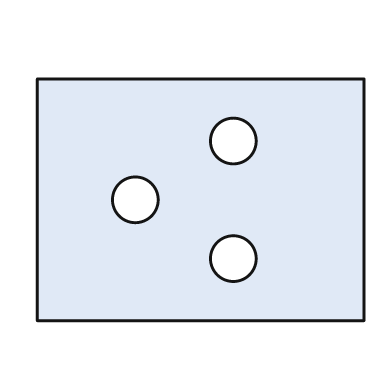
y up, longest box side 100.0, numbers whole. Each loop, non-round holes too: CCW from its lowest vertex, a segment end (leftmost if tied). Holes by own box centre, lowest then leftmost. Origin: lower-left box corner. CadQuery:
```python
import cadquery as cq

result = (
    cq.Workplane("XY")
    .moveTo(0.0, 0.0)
    .lineTo(100.0, 0.0)
    .lineTo(100.0, 74.0)
    .lineTo(0.0, 74.0)
    .close()
    .moveTo(60.0, 19.0)
    .circle(7.0)
    .moveTo(30.0, 37.0)
    .circle(7.0)
    .moveTo(60.0, 55.0)
    .circle(7.0)
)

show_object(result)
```